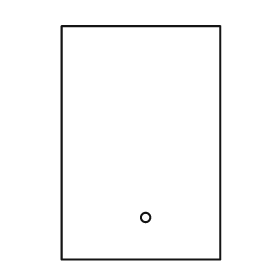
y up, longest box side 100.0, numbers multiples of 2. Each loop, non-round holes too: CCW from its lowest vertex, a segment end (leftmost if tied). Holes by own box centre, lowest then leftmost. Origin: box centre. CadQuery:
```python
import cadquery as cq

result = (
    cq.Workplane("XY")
    .moveTo(-34.0, -50.0)
    .lineTo(34.0, -50.0)
    .lineTo(34.0, 50.0)
    .lineTo(-34.0, 50.0)
    .close()
    .moveTo(2.0, -32.0)
    .circle(2.0)
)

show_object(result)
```